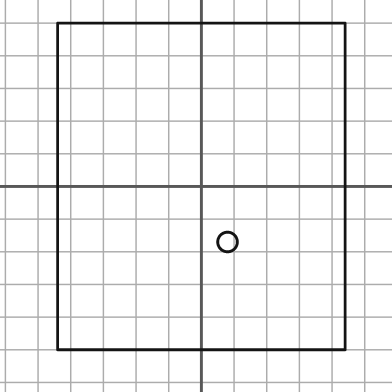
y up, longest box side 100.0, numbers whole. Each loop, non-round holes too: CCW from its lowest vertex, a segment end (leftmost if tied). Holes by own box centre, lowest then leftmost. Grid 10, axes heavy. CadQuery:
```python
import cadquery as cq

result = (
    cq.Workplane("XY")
    .moveTo(-44.0, -50.0)
    .lineTo(44.0, -50.0)
    .lineTo(44.0, 50.0)
    .lineTo(-44.0, 50.0)
    .close()
    .moveTo(8.0, -17.0)
    .circle(3.0)
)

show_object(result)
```